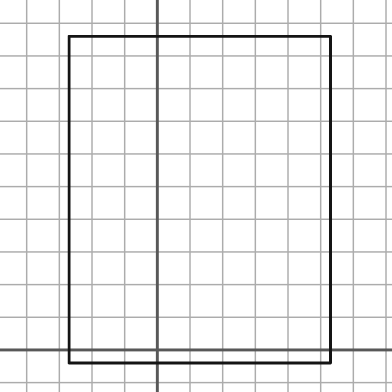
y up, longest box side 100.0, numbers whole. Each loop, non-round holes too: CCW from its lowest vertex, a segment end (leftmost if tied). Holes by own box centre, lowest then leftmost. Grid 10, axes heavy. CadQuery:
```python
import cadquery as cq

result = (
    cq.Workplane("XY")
    .moveTo(-27.0, -4.0)
    .lineTo(53.0, -4.0)
    .lineTo(53.0, 96.0)
    .lineTo(-27.0, 96.0)
    .close()
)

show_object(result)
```